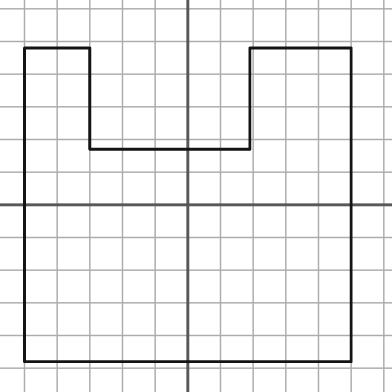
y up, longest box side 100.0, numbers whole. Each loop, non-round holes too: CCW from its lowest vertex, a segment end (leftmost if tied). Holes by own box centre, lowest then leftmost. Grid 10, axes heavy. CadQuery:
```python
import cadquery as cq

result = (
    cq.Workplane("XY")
    .moveTo(-50.0, -48.0)
    .lineTo(50.0, -48.0)
    .lineTo(50.0, 48.0)
    .lineTo(19.0, 48.0)
    .lineTo(19.0, 17.0)
    .lineTo(-30.0, 17.0)
    .lineTo(-30.0, 48.0)
    .lineTo(-50.0, 48.0)
    .close()
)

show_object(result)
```